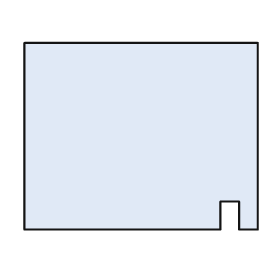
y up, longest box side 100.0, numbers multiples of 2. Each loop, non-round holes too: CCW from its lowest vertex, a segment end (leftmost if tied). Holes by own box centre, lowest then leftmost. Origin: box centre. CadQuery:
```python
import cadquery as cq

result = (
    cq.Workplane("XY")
    .moveTo(-50.0, -40.0)
    .lineTo(34.0, -40.0)
    .lineTo(34.0, -28.0)
    .lineTo(42.0, -28.0)
    .lineTo(42.0, -40.0)
    .lineTo(50.0, -40.0)
    .lineTo(50.0, 40.0)
    .lineTo(-50.0, 40.0)
    .close()
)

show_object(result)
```